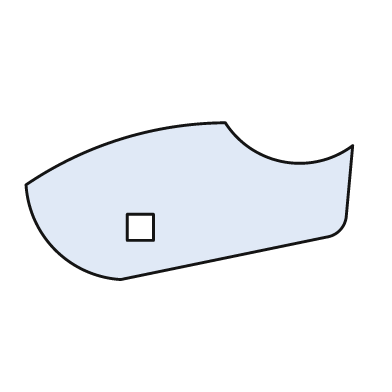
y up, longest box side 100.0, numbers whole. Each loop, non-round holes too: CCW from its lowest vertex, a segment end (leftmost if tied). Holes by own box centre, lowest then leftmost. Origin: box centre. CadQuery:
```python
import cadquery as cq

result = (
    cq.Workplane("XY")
    .moveTo(-21.0, -24.0)
    .lineTo(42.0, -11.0)
    .threePointArc((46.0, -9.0), (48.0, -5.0))
    .lineTo(50.0, 17.0)
    .threePointArc((29.0, 12.0), (11.0, 24.0))
    .threePointArc((-21.0, 19.0), (-50.0, 5.0))
    .threePointArc((-41.0, -15.0), (-21.0, -24.0))
    .close()
    .moveTo(-19.0, -12.0)
    .lineTo(-11.0, -12.0)
    .lineTo(-11.0, -4.0)
    .lineTo(-19.0, -4.0)
    .close()
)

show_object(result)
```